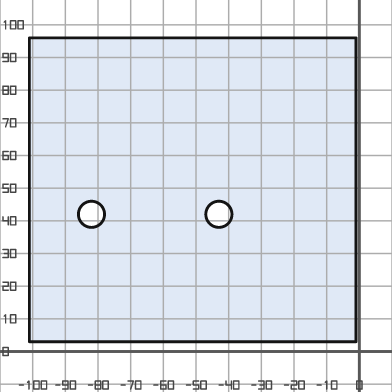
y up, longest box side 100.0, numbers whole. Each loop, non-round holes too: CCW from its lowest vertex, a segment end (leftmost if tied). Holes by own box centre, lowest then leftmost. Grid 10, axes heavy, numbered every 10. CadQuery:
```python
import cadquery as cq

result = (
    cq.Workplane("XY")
    .moveTo(-101.0, 3.0)
    .lineTo(-1.0, 3.0)
    .lineTo(-1.0, 96.0)
    .lineTo(-101.0, 96.0)
    .close()
    .moveTo(-82.0, 42.0)
    .circle(4.0)
    .moveTo(-43.0, 42.0)
    .circle(4.0)
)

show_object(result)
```